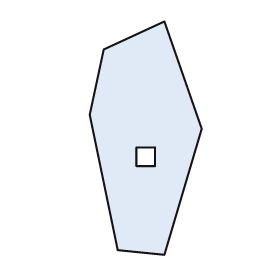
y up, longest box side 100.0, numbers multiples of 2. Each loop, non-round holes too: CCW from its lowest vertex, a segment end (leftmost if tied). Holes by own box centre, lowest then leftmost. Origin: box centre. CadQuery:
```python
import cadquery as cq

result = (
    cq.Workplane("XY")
    .moveTo(8.0, -50.0)
    .lineTo(24.0, 4.0)
    .lineTo(8.0, 50.0)
    .lineTo(-18.0, 38.0)
    .lineTo(-24.0, 10.0)
    .lineTo(-12.0, -48.0)
    .close()
    .moveTo(-4.0, -12.0)
    .lineTo(4.0, -12.0)
    .lineTo(4.0, -4.0)
    .lineTo(-4.0, -4.0)
    .close()
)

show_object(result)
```